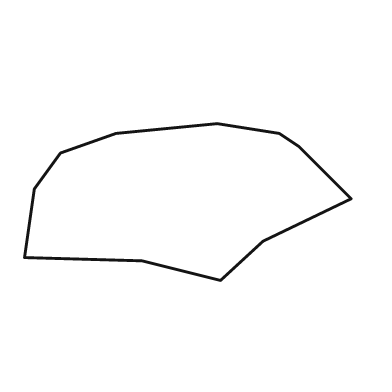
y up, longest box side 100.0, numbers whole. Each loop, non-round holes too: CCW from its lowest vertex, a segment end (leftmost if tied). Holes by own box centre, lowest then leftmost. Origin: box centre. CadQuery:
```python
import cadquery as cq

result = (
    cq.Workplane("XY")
    .moveTo(10.0, -24.0)
    .lineTo(23.0, -12.0)
    .lineTo(50.0, 1.0)
    .lineTo(34.0, 17.0)
    .lineTo(28.0, 21.0)
    .lineTo(9.0, 24.0)
    .lineTo(-22.0, 21.0)
    .lineTo(-39.0, 15.0)
    .lineTo(-47.0, 4.0)
    .lineTo(-50.0, -17.0)
    .lineTo(-14.0, -18.0)
    .close()
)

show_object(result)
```